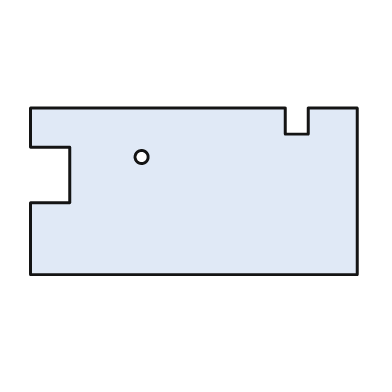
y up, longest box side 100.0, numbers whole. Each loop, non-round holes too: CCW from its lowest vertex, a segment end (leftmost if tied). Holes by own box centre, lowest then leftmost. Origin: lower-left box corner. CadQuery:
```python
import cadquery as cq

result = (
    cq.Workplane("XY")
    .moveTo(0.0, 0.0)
    .lineTo(100.0, 0.0)
    .lineTo(100.0, 51.0)
    .lineTo(85.0, 51.0)
    .lineTo(85.0, 43.0)
    .lineTo(78.0, 43.0)
    .lineTo(78.0, 51.0)
    .lineTo(0.0, 51.0)
    .lineTo(0.0, 39.0)
    .lineTo(12.0, 39.0)
    .lineTo(12.0, 22.0)
    .lineTo(0.0, 22.0)
    .close()
    .moveTo(34.0, 36.0)
    .circle(2.0)
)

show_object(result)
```